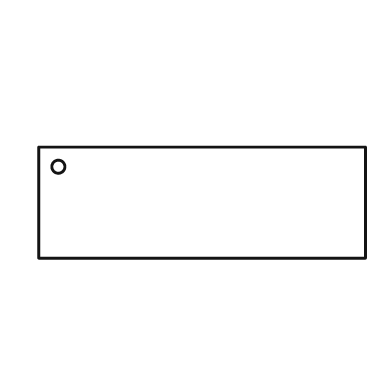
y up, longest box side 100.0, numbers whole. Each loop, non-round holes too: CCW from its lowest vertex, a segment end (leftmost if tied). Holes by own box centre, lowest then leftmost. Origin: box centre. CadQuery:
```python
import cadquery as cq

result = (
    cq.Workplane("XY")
    .moveTo(-50.0, -17.0)
    .lineTo(50.0, -17.0)
    .lineTo(50.0, 17.0)
    .lineTo(-50.0, 17.0)
    .close()
    .moveTo(-44.0, 11.0)
    .circle(2.0)
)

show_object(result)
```